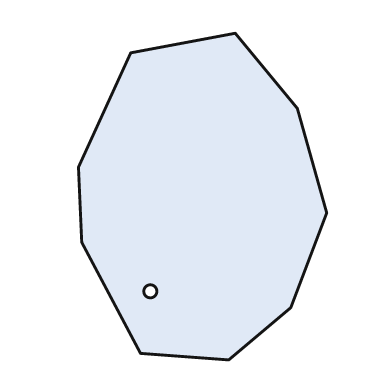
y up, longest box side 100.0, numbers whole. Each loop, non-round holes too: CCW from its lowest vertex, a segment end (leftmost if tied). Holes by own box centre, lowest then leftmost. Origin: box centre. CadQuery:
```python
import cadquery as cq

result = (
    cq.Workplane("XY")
    .moveTo(8.0, -50.0)
    .lineTo(27.0, -34.0)
    .lineTo(38.0, -5.0)
    .lineTo(29.0, 27.0)
    .lineTo(10.0, 50.0)
    .lineTo(-22.0, 44.0)
    .lineTo(-38.0, 9.0)
    .lineTo(-37.0, -14.0)
    .lineTo(-19.0, -48.0)
    .close()
    .moveTo(-16.0, -29.0)
    .circle(2.0)
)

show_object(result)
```